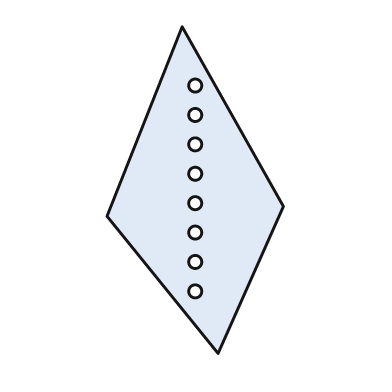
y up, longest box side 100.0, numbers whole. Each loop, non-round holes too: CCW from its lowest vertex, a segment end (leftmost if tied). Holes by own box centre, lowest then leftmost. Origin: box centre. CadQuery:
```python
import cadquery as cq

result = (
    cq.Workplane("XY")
    .moveTo(7.0, -50.0)
    .lineTo(27.0, -5.0)
    .lineTo(-4.0, 50.0)
    .lineTo(-27.0, -8.0)
    .close()
    .moveTo(0.0, -31.0)
    .circle(2.0)
    .moveTo(0.0, -22.0)
    .circle(2.0)
    .moveTo(0.0, -13.0)
    .circle(2.0)
    .moveTo(0.0, -4.0)
    .circle(2.0)
    .moveTo(0.0, 5.0)
    .circle(2.0)
    .moveTo(0.0, 14.0)
    .circle(2.0)
    .moveTo(0.0, 23.0)
    .circle(2.0)
    .moveTo(0.0, 32.0)
    .circle(2.0)
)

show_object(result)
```